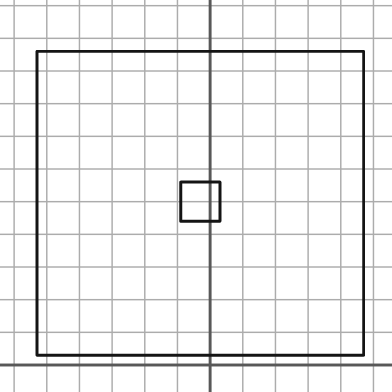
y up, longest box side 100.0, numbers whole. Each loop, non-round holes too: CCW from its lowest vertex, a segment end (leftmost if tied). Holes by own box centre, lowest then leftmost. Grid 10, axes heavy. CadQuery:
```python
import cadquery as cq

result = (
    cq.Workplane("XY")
    .moveTo(-53.0, 3.0)
    .lineTo(47.0, 3.0)
    .lineTo(47.0, 96.0)
    .lineTo(-53.0, 96.0)
    .close()
    .moveTo(-9.0, 44.0)
    .lineTo(3.0, 44.0)
    .lineTo(3.0, 56.0)
    .lineTo(-9.0, 56.0)
    .close()
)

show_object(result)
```